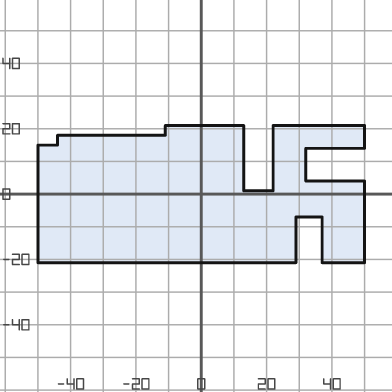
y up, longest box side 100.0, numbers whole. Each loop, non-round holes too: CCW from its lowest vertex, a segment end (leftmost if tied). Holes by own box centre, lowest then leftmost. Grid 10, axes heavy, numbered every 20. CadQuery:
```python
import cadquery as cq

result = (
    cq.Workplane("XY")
    .moveTo(-50.0, -21.0)
    .lineTo(29.0, -21.0)
    .lineTo(29.0, -7.0)
    .lineTo(37.0, -7.0)
    .lineTo(37.0, -21.0)
    .lineTo(50.0, -21.0)
    .lineTo(50.0, 4.0)
    .lineTo(32.0, 4.0)
    .lineTo(32.0, 14.0)
    .lineTo(50.0, 14.0)
    .lineTo(50.0, 21.0)
    .lineTo(22.0, 21.0)
    .lineTo(22.0, 1.0)
    .lineTo(13.0, 1.0)
    .lineTo(13.0, 21.0)
    .lineTo(-11.0, 21.0)
    .lineTo(-11.0, 18.0)
    .lineTo(-44.0, 18.0)
    .lineTo(-44.0, 15.0)
    .lineTo(-50.0, 15.0)
    .close()
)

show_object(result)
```